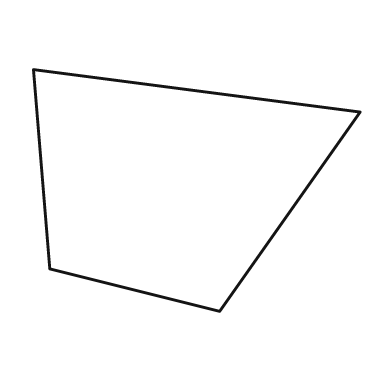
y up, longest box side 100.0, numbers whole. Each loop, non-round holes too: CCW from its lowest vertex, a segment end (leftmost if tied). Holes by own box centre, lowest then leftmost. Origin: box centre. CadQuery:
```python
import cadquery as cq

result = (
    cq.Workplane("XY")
    .moveTo(7.0, -37.0)
    .lineTo(50.0, 24.0)
    .lineTo(-50.0, 37.0)
    .lineTo(-45.0, -24.0)
    .close()
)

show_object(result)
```